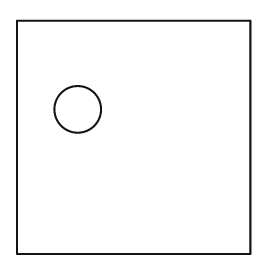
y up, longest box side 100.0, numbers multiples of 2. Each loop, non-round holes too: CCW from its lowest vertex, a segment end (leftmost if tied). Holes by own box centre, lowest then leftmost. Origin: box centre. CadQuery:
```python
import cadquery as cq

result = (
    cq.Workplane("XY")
    .moveTo(-50.0, -50.0)
    .lineTo(50.0, -50.0)
    .lineTo(50.0, 50.0)
    .lineTo(-50.0, 50.0)
    .close()
    .moveTo(-24.0, 12.0)
    .circle(10.0)
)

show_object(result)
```